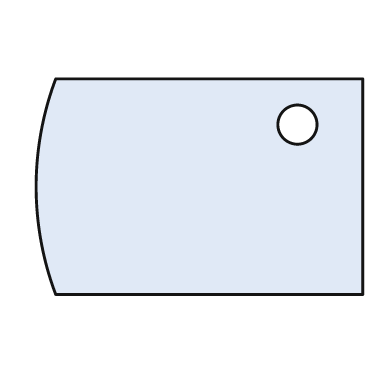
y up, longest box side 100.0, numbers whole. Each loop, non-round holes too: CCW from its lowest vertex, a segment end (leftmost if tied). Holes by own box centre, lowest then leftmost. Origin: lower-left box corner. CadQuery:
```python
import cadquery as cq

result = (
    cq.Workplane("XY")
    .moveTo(6.0, 0.0)
    .lineTo(100.0, 0.0)
    .lineTo(100.0, 66.0)
    .lineTo(6.0, 66.0)
    .threePointArc((0.0, 33.0), (6.0, 0.0))
    .close()
    .moveTo(80.0, 52.0)
    .circle(6.0)
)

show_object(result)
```